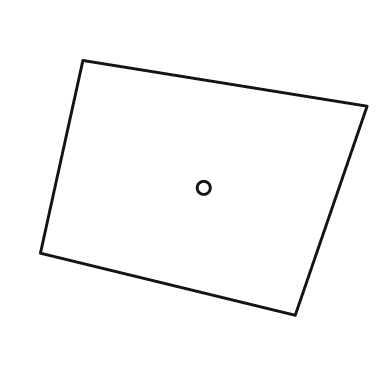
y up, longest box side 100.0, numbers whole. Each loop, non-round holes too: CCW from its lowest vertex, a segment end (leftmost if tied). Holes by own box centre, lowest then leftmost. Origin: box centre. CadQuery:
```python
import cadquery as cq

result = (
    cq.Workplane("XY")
    .moveTo(28.0, -39.0)
    .lineTo(50.0, 25.0)
    .lineTo(-37.0, 39.0)
    .lineTo(-50.0, -20.0)
    .close()
    .moveTo(0.0, 0.0)
    .circle(2.0)
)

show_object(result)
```